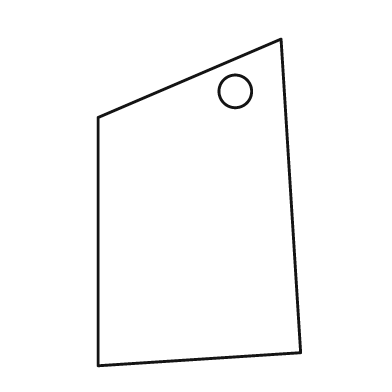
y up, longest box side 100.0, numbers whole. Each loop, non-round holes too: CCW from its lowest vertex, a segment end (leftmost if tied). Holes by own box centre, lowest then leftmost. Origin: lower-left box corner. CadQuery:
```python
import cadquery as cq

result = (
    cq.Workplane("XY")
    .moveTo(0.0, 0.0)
    .lineTo(62.0, 4.0)
    .lineTo(56.0, 100.0)
    .lineTo(0.0, 76.0)
    .close()
    .moveTo(42.0, 84.0)
    .circle(5.0)
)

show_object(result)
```